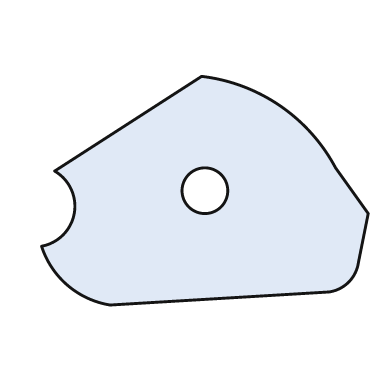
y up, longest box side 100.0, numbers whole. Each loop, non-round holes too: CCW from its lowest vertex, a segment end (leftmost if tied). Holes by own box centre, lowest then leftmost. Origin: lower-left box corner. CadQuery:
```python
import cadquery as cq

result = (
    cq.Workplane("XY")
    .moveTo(21.0, 0.0)
    .lineTo(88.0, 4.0)
    .threePointArc((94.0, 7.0), (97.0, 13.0))
    .lineTo(100.0, 28.0)
    .lineTo(90.0, 42.0)
    .threePointArc((73.0, 61.0), (49.0, 70.0))
    .lineTo(4.0, 41.0)
    .threePointArc((10.0, 28.0), (0.0, 18.0))
    .threePointArc((8.0, 6.0), (21.0, 0.0))
    .close()
    .moveTo(50.0, 35.0)
    .circle(7.0)
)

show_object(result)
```